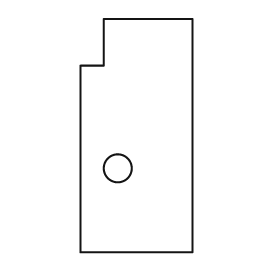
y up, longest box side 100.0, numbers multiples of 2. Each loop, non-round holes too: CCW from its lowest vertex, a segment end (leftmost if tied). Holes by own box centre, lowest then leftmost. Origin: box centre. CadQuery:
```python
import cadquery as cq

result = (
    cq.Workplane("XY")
    .moveTo(-24.0, -50.0)
    .lineTo(24.0, -50.0)
    .lineTo(24.0, 50.0)
    .lineTo(-14.0, 50.0)
    .lineTo(-14.0, 30.0)
    .lineTo(-24.0, 30.0)
    .close()
    .moveTo(-8.0, -14.0)
    .circle(6.0)
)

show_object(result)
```